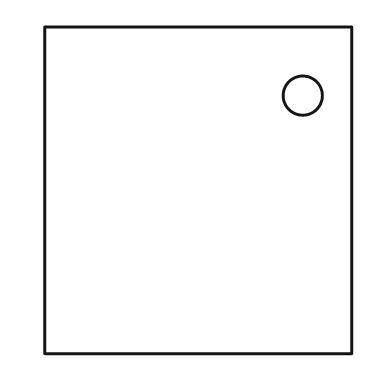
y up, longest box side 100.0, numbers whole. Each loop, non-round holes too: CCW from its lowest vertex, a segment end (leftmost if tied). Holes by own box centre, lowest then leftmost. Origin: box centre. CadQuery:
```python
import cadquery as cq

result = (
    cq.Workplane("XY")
    .moveTo(-47.0, -50.0)
    .lineTo(47.0, -50.0)
    .lineTo(47.0, 50.0)
    .lineTo(-47.0, 50.0)
    .close()
    .moveTo(32.0, 29.0)
    .circle(6.0)
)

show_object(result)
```